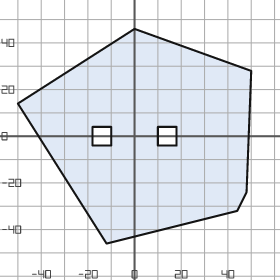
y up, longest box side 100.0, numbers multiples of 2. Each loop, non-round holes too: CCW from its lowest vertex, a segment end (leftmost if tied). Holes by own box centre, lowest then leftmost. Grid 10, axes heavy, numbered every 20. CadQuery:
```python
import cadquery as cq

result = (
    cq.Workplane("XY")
    .moveTo(-12.0, -46.0)
    .lineTo(44.0, -32.0)
    .lineTo(48.0, -24.0)
    .lineTo(50.0, 28.0)
    .lineTo(0.0, 46.0)
    .lineTo(-50.0, 14.0)
    .close()
    .moveTo(-18.0, -4.0)
    .lineTo(-10.0, -4.0)
    .lineTo(-10.0, 4.0)
    .lineTo(-18.0, 4.0)
    .close()
    .moveTo(10.0, -4.0)
    .lineTo(18.0, -4.0)
    .lineTo(18.0, 4.0)
    .lineTo(10.0, 4.0)
    .close()
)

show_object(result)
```